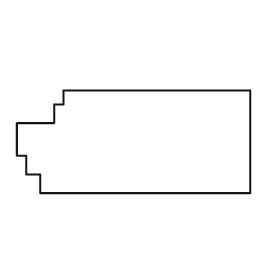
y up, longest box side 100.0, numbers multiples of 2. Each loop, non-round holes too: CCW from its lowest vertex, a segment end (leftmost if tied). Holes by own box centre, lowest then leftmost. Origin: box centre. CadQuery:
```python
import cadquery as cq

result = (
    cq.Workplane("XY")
    .moveTo(-40.0, -22.0)
    .lineTo(50.0, -22.0)
    .lineTo(50.0, 22.0)
    .lineTo(-30.0, 22.0)
    .lineTo(-30.0, 16.0)
    .lineTo(-34.0, 16.0)
    .lineTo(-34.0, 8.0)
    .lineTo(-50.0, 8.0)
    .lineTo(-50.0, -6.0)
    .lineTo(-46.0, -6.0)
    .lineTo(-46.0, -14.0)
    .lineTo(-40.0, -14.0)
    .close()
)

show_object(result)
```